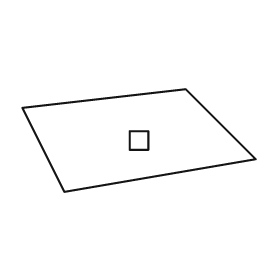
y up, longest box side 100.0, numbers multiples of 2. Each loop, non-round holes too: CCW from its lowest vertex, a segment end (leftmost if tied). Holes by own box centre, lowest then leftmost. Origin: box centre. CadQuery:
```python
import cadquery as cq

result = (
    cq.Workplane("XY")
    .moveTo(-32.0, -22.0)
    .lineTo(50.0, -8.0)
    .lineTo(20.0, 22.0)
    .lineTo(-50.0, 14.0)
    .close()
    .moveTo(-4.0, -4.0)
    .lineTo(4.0, -4.0)
    .lineTo(4.0, 4.0)
    .lineTo(-4.0, 4.0)
    .close()
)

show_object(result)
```